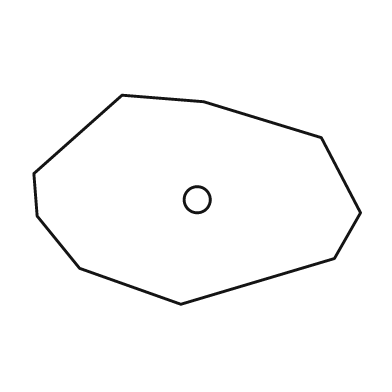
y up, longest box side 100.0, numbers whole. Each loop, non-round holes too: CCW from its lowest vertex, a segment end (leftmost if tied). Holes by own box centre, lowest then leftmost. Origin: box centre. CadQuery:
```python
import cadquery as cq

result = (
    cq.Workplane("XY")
    .moveTo(-5.0, -32.0)
    .lineTo(42.0, -18.0)
    .lineTo(50.0, -4.0)
    .lineTo(38.0, 19.0)
    .lineTo(2.0, 30.0)
    .lineTo(-23.0, 32.0)
    .lineTo(-50.0, 8.0)
    .lineTo(-49.0, -5.0)
    .lineTo(-36.0, -21.0)
    .close()
    .moveTo(0.0, 0.0)
    .circle(4.0)
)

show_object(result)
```